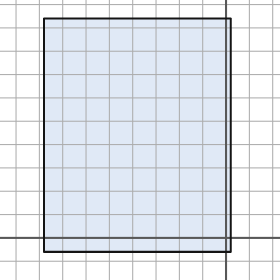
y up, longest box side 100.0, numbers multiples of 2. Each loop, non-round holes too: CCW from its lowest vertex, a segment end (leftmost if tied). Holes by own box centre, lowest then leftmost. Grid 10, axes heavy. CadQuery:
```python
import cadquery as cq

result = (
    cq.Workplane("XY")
    .moveTo(-78.0, -6.0)
    .lineTo(2.0, -6.0)
    .lineTo(2.0, 94.0)
    .lineTo(-78.0, 94.0)
    .close()
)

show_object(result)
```